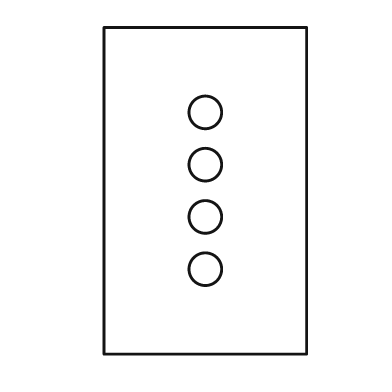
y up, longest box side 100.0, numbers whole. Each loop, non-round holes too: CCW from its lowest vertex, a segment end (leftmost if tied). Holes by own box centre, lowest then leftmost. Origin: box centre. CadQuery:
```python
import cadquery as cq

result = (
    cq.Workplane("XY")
    .moveTo(-31.0, -50.0)
    .lineTo(31.0, -50.0)
    .lineTo(31.0, 50.0)
    .lineTo(-31.0, 50.0)
    .close()
    .moveTo(0.0, -24.0)
    .circle(5.0)
    .moveTo(0.0, -8.0)
    .circle(5.0)
    .moveTo(0.0, 8.0)
    .circle(5.0)
    .moveTo(0.0, 24.0)
    .circle(5.0)
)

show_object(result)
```